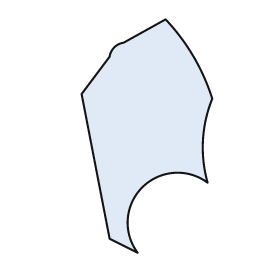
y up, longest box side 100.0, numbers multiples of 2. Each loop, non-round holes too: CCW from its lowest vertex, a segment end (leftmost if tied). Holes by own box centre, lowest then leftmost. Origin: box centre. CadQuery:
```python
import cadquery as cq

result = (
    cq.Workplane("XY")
    .moveTo(-4.0, -50.0)
    .threePointArc((-2.0, -22.0), (26.0, -20.0))
    .threePointArc((24.0, -2.0), (28.0, 16.0))
    .threePointArc((20.0, 34.0), (8.0, 50.0))
    .lineTo(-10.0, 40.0)
    .threePointArc((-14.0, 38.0), (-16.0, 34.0))
    .lineTo(-28.0, 18.0)
    .lineTo(-16.0, -44.0)
    .close()
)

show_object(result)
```